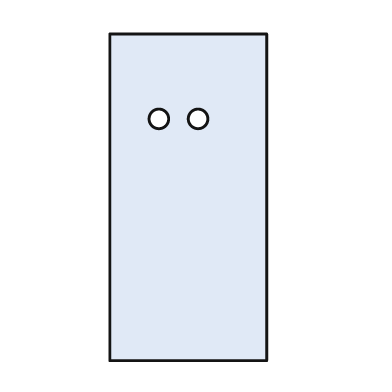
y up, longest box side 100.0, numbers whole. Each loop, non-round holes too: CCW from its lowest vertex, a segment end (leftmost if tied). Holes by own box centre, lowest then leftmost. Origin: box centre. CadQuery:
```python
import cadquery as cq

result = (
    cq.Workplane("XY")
    .moveTo(-24.0, -50.0)
    .lineTo(24.0, -50.0)
    .lineTo(24.0, 50.0)
    .lineTo(-24.0, 50.0)
    .close()
    .moveTo(-9.0, 24.0)
    .circle(3.0)
    .moveTo(3.0, 24.0)
    .circle(3.0)
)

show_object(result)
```